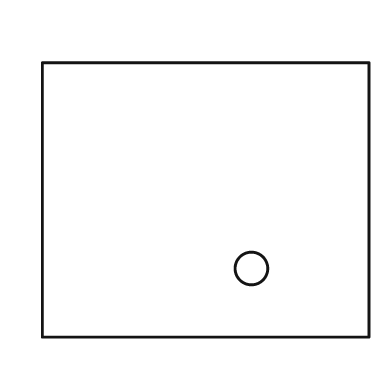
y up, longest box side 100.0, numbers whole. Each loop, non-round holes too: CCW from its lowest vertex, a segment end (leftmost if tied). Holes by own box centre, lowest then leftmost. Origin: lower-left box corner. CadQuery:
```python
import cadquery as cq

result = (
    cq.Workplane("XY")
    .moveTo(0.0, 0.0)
    .lineTo(100.0, 0.0)
    .lineTo(100.0, 84.0)
    .lineTo(0.0, 84.0)
    .close()
    .moveTo(64.0, 21.0)
    .circle(5.0)
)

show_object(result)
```